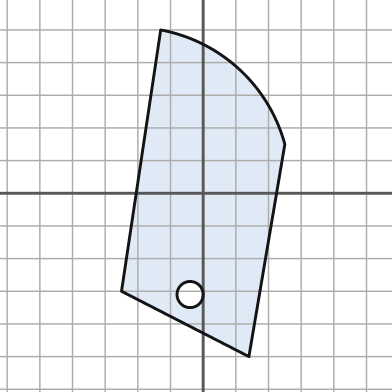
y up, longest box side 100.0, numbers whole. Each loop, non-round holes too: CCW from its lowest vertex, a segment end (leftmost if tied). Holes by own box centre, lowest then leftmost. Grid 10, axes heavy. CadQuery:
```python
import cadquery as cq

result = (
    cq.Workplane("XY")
    .moveTo(14.0, -50.0)
    .lineTo(25.0, 15.0)
    .threePointArc((11.0, 38.0), (-13.0, 50.0))
    .lineTo(-25.0, -30.0)
    .close()
    .moveTo(-4.0, -31.0)
    .circle(4.0)
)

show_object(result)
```